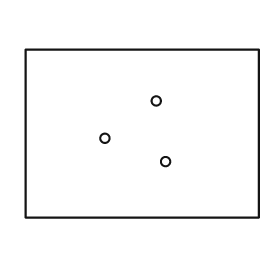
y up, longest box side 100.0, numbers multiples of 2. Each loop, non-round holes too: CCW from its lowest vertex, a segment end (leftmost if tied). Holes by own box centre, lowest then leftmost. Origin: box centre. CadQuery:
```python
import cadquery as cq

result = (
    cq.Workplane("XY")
    .moveTo(-50.0, -36.0)
    .lineTo(50.0, -36.0)
    .lineTo(50.0, 36.0)
    .lineTo(-50.0, 36.0)
    .close()
    .moveTo(10.0, -12.0)
    .circle(2.0)
    .moveTo(-16.0, -2.0)
    .circle(2.0)
    .moveTo(6.0, 14.0)
    .circle(2.0)
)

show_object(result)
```